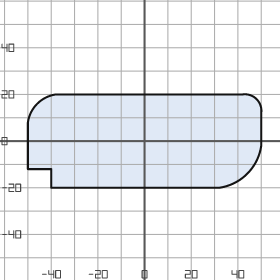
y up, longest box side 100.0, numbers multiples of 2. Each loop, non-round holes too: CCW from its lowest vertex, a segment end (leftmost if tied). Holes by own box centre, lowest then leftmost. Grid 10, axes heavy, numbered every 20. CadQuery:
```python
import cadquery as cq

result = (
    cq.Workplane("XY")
    .moveTo(-40.0, -20.0)
    .lineTo(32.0, -20.0)
    .threePointArc((44.0, -14.0), (50.0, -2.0))
    .lineTo(50.0, 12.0)
    .threePointArc((48.0, 18.0), (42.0, 20.0))
    .lineTo(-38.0, 20.0)
    .threePointArc((-46.0, 16.0), (-50.0, 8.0))
    .lineTo(-50.0, -12.0)
    .lineTo(-40.0, -12.0)
    .close()
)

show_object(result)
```